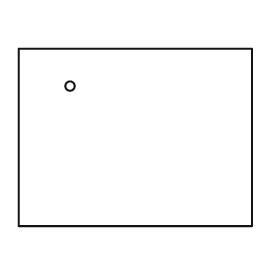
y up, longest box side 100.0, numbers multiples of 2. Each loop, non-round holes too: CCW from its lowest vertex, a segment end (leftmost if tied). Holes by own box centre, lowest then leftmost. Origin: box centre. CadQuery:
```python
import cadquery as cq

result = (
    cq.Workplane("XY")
    .moveTo(-50.0, -38.0)
    .lineTo(50.0, -38.0)
    .lineTo(50.0, 38.0)
    .lineTo(-50.0, 38.0)
    .close()
    .moveTo(-28.0, 22.0)
    .circle(2.0)
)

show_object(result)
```